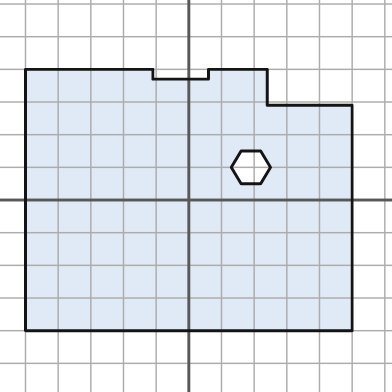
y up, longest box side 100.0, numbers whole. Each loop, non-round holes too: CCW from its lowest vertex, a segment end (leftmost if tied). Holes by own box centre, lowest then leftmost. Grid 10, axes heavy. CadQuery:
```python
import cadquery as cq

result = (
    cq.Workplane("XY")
    .moveTo(-50.0, -40.0)
    .lineTo(50.0, -40.0)
    .lineTo(50.0, 29.0)
    .lineTo(24.0, 29.0)
    .lineTo(24.0, 40.0)
    .lineTo(6.0, 40.0)
    .lineTo(6.0, 37.0)
    .lineTo(-11.0, 37.0)
    .lineTo(-11.0, 40.0)
    .lineTo(-50.0, 40.0)
    .close()
    .moveTo(16.0, 5.0)
    .lineTo(22.0, 5.0)
    .lineTo(25.0, 10.0)
    .lineTo(22.0, 15.0)
    .lineTo(16.0, 15.0)
    .lineTo(13.0, 10.0)
    .close()
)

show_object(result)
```